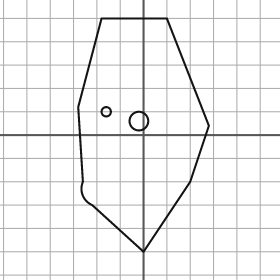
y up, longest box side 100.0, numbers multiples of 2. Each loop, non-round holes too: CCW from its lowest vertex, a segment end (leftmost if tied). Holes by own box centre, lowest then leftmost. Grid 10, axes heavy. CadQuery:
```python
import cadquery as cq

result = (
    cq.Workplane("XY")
    .moveTo(0.0, -50.0)
    .lineTo(20.0, -20.0)
    .lineTo(28.0, 4.0)
    .lineTo(10.0, 50.0)
    .lineTo(-18.0, 50.0)
    .lineTo(-28.0, 12.0)
    .lineTo(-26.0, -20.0)
    .threePointArc((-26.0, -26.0), (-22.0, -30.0))
    .close()
    .moveTo(-2.0, 6.0)
    .circle(4.0)
    .moveTo(-16.0, 10.0)
    .circle(2.0)
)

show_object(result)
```